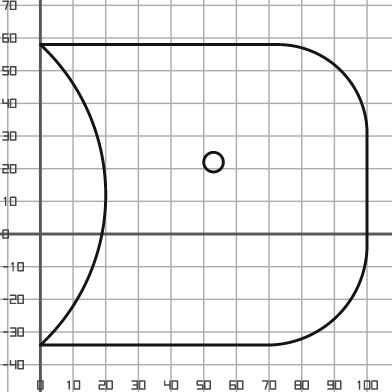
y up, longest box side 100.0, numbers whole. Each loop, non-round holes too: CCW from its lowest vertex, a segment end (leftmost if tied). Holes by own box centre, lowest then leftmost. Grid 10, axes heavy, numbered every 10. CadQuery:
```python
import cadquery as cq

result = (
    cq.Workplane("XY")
    .moveTo(0.0, -34.0)
    .lineTo(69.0, -34.0)
    .threePointArc((91.0, -25.0), (100.0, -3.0))
    .lineTo(100.0, 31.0)
    .threePointArc((92.0, 50.0), (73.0, 58.0))
    .lineTo(0.0, 58.0)
    .threePointArc((20.0, 12.0), (0.0, -34.0))
    .close()
    .moveTo(53.0, 22.0)
    .circle(3.0)
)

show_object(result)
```